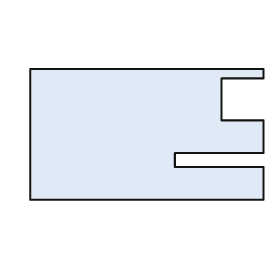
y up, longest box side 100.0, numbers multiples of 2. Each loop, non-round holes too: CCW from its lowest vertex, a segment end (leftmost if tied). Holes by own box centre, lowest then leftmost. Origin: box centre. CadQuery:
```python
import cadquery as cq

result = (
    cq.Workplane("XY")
    .moveTo(-50.0, -28.0)
    .lineTo(50.0, -28.0)
    .lineTo(50.0, -14.0)
    .lineTo(12.0, -14.0)
    .lineTo(12.0, -8.0)
    .lineTo(50.0, -8.0)
    .lineTo(50.0, 6.0)
    .lineTo(32.0, 6.0)
    .lineTo(32.0, 24.0)
    .lineTo(50.0, 24.0)
    .lineTo(50.0, 28.0)
    .lineTo(-50.0, 28.0)
    .close()
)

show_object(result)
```